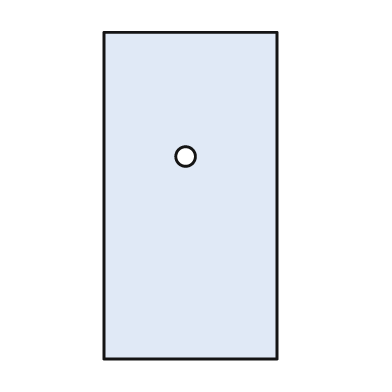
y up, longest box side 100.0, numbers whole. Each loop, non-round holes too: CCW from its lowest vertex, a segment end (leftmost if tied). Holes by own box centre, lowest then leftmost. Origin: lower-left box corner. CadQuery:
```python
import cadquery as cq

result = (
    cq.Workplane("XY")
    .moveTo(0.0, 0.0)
    .lineTo(53.0, 0.0)
    .lineTo(53.0, 100.0)
    .lineTo(0.0, 100.0)
    .close()
    .moveTo(25.0, 62.0)
    .circle(3.0)
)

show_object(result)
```